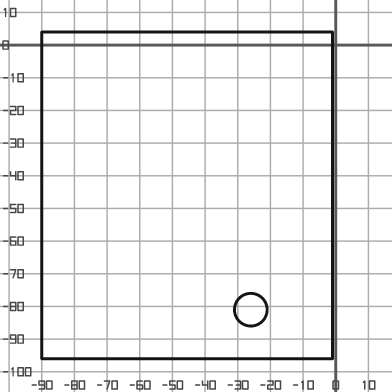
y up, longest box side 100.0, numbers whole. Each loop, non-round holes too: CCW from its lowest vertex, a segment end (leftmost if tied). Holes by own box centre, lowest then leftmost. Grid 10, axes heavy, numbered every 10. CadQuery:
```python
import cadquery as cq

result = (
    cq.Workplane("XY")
    .moveTo(-90.0, -96.0)
    .lineTo(-1.0, -96.0)
    .lineTo(-1.0, 4.0)
    .lineTo(-90.0, 4.0)
    .close()
    .moveTo(-26.0, -81.0)
    .circle(5.0)
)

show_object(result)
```